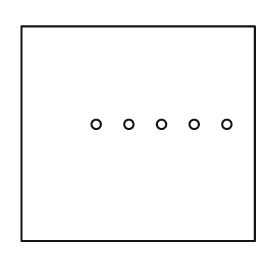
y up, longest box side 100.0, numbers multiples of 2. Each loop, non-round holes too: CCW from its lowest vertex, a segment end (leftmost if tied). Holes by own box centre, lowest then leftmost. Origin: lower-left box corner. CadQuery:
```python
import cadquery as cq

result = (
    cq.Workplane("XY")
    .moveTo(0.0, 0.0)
    .lineTo(100.0, 0.0)
    .lineTo(100.0, 92.0)
    .lineTo(0.0, 92.0)
    .close()
    .moveTo(32.0, 50.0)
    .circle(2.0)
    .moveTo(46.0, 50.0)
    .circle(2.0)
    .moveTo(60.0, 50.0)
    .circle(2.0)
    .moveTo(74.0, 50.0)
    .circle(2.0)
    .moveTo(88.0, 50.0)
    .circle(2.0)
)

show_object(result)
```